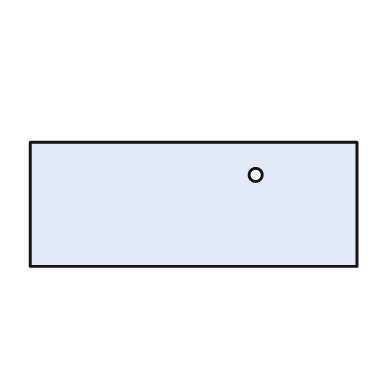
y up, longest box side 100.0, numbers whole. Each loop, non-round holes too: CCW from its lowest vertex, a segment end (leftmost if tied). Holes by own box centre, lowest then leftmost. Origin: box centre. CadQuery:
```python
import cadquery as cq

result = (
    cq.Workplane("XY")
    .moveTo(-50.0, -19.0)
    .lineTo(50.0, -19.0)
    .lineTo(50.0, 19.0)
    .lineTo(-50.0, 19.0)
    .close()
    .moveTo(19.0, 9.0)
    .circle(2.0)
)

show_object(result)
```